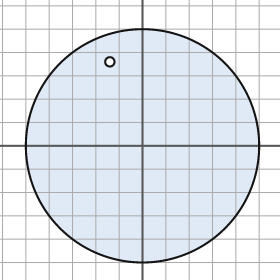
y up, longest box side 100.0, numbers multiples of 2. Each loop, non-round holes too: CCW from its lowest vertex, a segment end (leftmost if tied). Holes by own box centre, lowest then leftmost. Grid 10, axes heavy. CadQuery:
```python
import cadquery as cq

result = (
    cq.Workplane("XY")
    .moveTo(0.0, 0.0)
    .circle(50.0)
    .moveTo(-14.0, 36.0)
    .circle(2.0)
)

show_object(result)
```